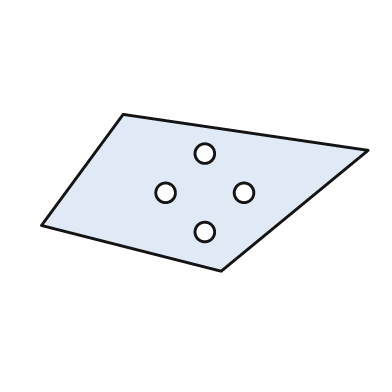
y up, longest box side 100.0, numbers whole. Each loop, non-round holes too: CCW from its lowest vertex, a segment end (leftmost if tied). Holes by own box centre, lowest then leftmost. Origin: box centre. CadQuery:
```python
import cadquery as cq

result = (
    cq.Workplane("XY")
    .moveTo(5.0, -24.0)
    .lineTo(50.0, 13.0)
    .lineTo(-25.0, 24.0)
    .lineTo(-50.0, -10.0)
    .close()
    .moveTo(0.0, -12.0)
    .circle(3.0)
    .moveTo(-12.0, 0.0)
    .circle(3.0)
    .moveTo(12.0, 0.0)
    .circle(3.0)
    .moveTo(0.0, 12.0)
    .circle(3.0)
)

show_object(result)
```